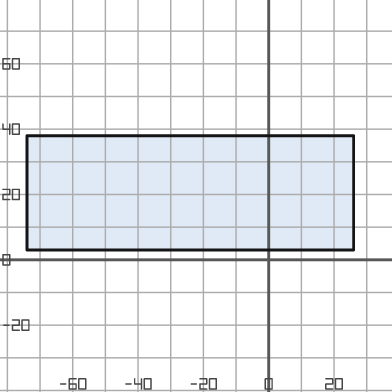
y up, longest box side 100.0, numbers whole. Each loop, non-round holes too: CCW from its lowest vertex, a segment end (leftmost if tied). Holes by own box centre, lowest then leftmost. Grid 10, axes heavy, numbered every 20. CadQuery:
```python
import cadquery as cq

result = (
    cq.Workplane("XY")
    .moveTo(-74.0, 3.0)
    .lineTo(26.0, 3.0)
    .lineTo(26.0, 38.0)
    .lineTo(-74.0, 38.0)
    .close()
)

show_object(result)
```